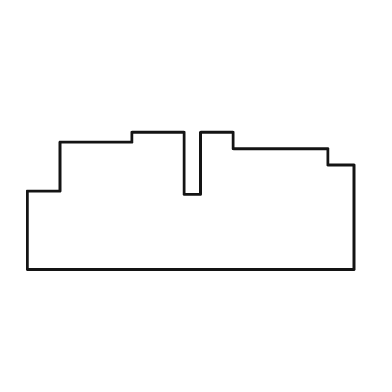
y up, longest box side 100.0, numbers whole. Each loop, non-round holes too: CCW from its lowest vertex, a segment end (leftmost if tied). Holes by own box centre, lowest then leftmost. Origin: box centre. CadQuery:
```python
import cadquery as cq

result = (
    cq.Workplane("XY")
    .moveTo(-50.0, -21.0)
    .lineTo(50.0, -21.0)
    .lineTo(50.0, 11.0)
    .lineTo(42.0, 11.0)
    .lineTo(42.0, 16.0)
    .lineTo(13.0, 16.0)
    .lineTo(13.0, 21.0)
    .lineTo(3.0, 21.0)
    .lineTo(3.0, 2.0)
    .lineTo(-2.0, 2.0)
    .lineTo(-2.0, 21.0)
    .lineTo(-18.0, 21.0)
    .lineTo(-18.0, 18.0)
    .lineTo(-40.0, 18.0)
    .lineTo(-40.0, 3.0)
    .lineTo(-50.0, 3.0)
    .close()
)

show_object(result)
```